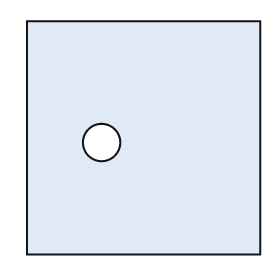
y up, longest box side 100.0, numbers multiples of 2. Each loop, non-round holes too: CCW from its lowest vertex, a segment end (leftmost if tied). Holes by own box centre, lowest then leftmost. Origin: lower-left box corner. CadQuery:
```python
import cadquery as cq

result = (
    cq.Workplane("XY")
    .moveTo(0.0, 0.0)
    .lineTo(100.0, 0.0)
    .lineTo(100.0, 100.0)
    .lineTo(0.0, 100.0)
    .close()
    .moveTo(32.0, 48.0)
    .circle(8.0)
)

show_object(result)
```